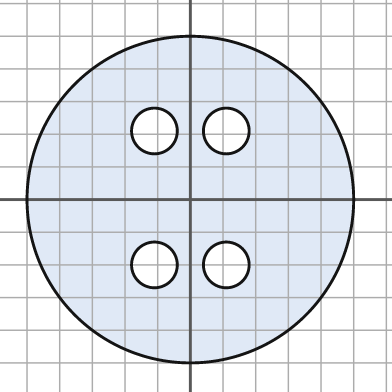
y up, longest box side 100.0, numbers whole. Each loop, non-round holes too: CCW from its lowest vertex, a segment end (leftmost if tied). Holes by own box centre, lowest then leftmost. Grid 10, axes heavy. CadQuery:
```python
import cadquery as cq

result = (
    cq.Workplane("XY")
    .moveTo(0.0, 0.0)
    .circle(50.0)
    .moveTo(-11.0, -20.0)
    .circle(7.0)
    .moveTo(11.0, -20.0)
    .circle(7.0)
    .moveTo(-11.0, 21.0)
    .circle(7.0)
    .moveTo(11.0, 21.0)
    .circle(7.0)
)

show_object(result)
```